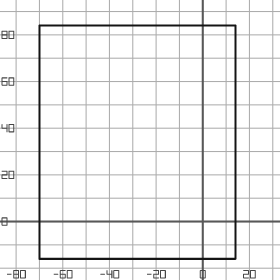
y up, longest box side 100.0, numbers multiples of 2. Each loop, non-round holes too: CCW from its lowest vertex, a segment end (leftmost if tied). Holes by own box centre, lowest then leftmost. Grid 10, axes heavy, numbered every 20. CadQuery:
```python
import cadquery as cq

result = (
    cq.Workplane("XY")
    .moveTo(-70.0, -16.0)
    .lineTo(14.0, -16.0)
    .lineTo(14.0, 84.0)
    .lineTo(-70.0, 84.0)
    .close()
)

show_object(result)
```